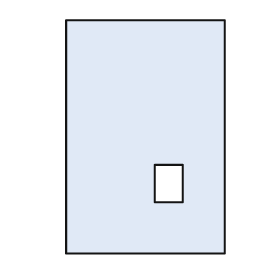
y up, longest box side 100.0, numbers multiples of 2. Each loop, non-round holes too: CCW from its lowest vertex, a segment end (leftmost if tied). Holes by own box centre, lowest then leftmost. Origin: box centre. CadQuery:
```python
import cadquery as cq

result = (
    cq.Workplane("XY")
    .moveTo(-34.0, -50.0)
    .lineTo(34.0, -50.0)
    .lineTo(34.0, 50.0)
    .lineTo(-34.0, 50.0)
    .close()
    .moveTo(4.0, -28.0)
    .lineTo(16.0, -28.0)
    .lineTo(16.0, -12.0)
    .lineTo(4.0, -12.0)
    .close()
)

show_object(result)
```